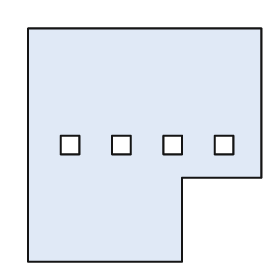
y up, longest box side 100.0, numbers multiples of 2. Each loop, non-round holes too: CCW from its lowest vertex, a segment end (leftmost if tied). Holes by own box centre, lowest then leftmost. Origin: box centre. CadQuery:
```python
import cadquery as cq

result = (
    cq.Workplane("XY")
    .moveTo(-50.0, -50.0)
    .lineTo(16.0, -50.0)
    .lineTo(16.0, -14.0)
    .lineTo(50.0, -14.0)
    .lineTo(50.0, 50.0)
    .lineTo(-50.0, 50.0)
    .close()
    .moveTo(-36.0, -4.0)
    .lineTo(-28.0, -4.0)
    .lineTo(-28.0, 4.0)
    .lineTo(-36.0, 4.0)
    .close()
    .moveTo(-14.0, -4.0)
    .lineTo(-6.0, -4.0)
    .lineTo(-6.0, 4.0)
    .lineTo(-14.0, 4.0)
    .close()
    .moveTo(8.0, -4.0)
    .lineTo(16.0, -4.0)
    .lineTo(16.0, 4.0)
    .lineTo(8.0, 4.0)
    .close()
    .moveTo(30.0, -4.0)
    .lineTo(38.0, -4.0)
    .lineTo(38.0, 4.0)
    .lineTo(30.0, 4.0)
    .close()
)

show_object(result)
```